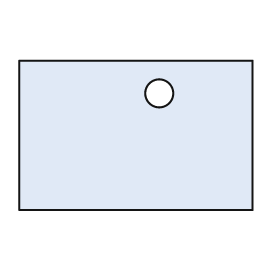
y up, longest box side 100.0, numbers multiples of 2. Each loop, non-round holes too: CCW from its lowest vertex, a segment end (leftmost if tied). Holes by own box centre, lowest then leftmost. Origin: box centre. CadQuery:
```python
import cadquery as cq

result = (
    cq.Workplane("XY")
    .moveTo(-50.0, -32.0)
    .lineTo(50.0, -32.0)
    .lineTo(50.0, 32.0)
    .lineTo(-50.0, 32.0)
    .close()
    .moveTo(10.0, 18.0)
    .circle(6.0)
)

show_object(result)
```